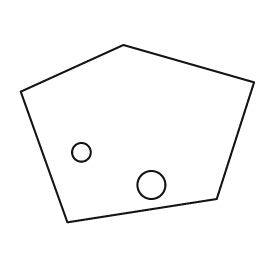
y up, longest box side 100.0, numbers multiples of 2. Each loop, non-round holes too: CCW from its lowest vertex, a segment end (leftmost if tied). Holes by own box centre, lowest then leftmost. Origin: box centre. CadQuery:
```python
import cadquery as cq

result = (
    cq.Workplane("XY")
    .moveTo(-30.0, -38.0)
    .lineTo(34.0, -28.0)
    .lineTo(50.0, 22.0)
    .lineTo(-6.0, 38.0)
    .lineTo(-50.0, 18.0)
    .close()
    .moveTo(6.0, -22.0)
    .circle(6.0)
    .moveTo(-24.0, -8.0)
    .circle(4.0)
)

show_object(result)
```